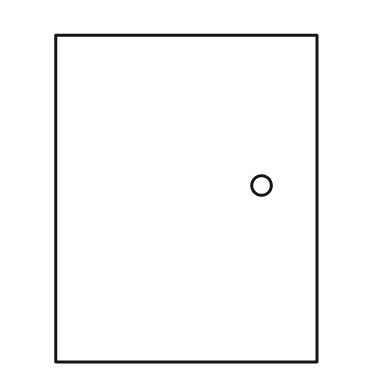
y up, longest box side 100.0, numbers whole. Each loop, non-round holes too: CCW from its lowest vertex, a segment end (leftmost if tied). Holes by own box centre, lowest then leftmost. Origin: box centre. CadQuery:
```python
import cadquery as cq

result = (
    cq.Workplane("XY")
    .moveTo(-40.0, -50.0)
    .lineTo(40.0, -50.0)
    .lineTo(40.0, 50.0)
    .lineTo(-40.0, 50.0)
    .close()
    .moveTo(23.0, 4.0)
    .circle(3.0)
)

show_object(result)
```